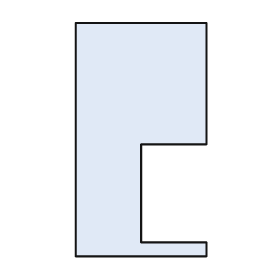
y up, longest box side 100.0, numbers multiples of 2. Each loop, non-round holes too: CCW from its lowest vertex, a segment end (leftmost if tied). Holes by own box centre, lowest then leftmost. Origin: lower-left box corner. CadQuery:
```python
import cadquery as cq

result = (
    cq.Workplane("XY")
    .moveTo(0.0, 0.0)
    .lineTo(56.0, 0.0)
    .lineTo(56.0, 6.0)
    .lineTo(28.0, 6.0)
    .lineTo(28.0, 48.0)
    .lineTo(56.0, 48.0)
    .lineTo(56.0, 100.0)
    .lineTo(0.0, 100.0)
    .close()
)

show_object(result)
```